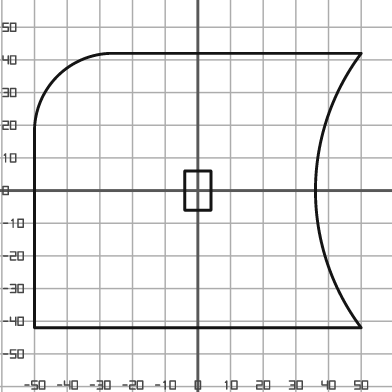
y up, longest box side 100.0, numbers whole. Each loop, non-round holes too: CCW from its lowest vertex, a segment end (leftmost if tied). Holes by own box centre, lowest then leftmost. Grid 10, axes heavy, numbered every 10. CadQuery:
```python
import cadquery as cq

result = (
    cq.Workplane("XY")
    .moveTo(-50.0, -42.0)
    .lineTo(50.0, -42.0)
    .threePointArc((36.0, 0.0), (50.0, 42.0))
    .lineTo(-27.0, 42.0)
    .threePointArc((-43.0, 35.0), (-50.0, 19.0))
    .close()
    .moveTo(-4.0, -6.0)
    .lineTo(4.0, -6.0)
    .lineTo(4.0, 6.0)
    .lineTo(-4.0, 6.0)
    .close()
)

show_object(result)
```